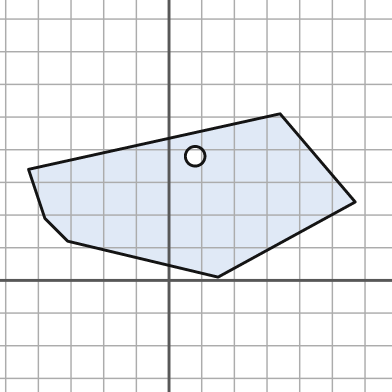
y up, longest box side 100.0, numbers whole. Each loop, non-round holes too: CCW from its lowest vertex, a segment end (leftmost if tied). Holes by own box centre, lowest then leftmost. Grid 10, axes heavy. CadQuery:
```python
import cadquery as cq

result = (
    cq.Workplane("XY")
    .moveTo(15.0, 1.0)
    .lineTo(57.0, 24.0)
    .lineTo(34.0, 51.0)
    .lineTo(-43.0, 34.0)
    .lineTo(-38.0, 19.0)
    .lineTo(-31.0, 12.0)
    .close()
    .moveTo(8.0, 38.0)
    .circle(3.0)
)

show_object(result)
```